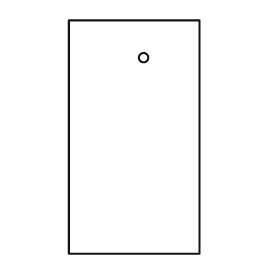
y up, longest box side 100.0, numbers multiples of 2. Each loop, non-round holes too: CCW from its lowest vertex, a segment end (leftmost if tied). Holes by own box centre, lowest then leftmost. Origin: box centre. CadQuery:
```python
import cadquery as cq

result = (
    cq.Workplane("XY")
    .moveTo(-28.0, -50.0)
    .lineTo(28.0, -50.0)
    .lineTo(28.0, 50.0)
    .lineTo(-28.0, 50.0)
    .close()
    .moveTo(4.0, 34.0)
    .circle(2.0)
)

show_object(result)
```